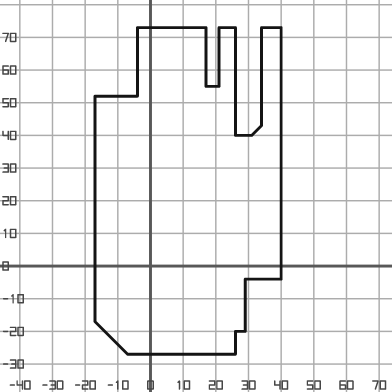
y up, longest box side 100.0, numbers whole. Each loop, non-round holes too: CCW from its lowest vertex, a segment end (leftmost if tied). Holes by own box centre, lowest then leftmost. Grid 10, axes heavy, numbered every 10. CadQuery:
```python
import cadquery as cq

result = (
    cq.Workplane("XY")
    .moveTo(-7.0, -27.0)
    .lineTo(26.0, -27.0)
    .lineTo(26.0, -20.0)
    .lineTo(29.0, -20.0)
    .lineTo(29.0, -4.0)
    .lineTo(40.0, -4.0)
    .lineTo(40.0, 73.0)
    .lineTo(34.0, 73.0)
    .lineTo(34.0, 43.0)
    .lineTo(31.0, 40.0)
    .lineTo(26.0, 40.0)
    .lineTo(26.0, 73.0)
    .lineTo(21.0, 73.0)
    .lineTo(21.0, 55.0)
    .lineTo(17.0, 55.0)
    .lineTo(17.0, 73.0)
    .lineTo(-4.0, 73.0)
    .lineTo(-4.0, 52.0)
    .lineTo(-17.0, 52.0)
    .lineTo(-17.0, -17.0)
    .close()
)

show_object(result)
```